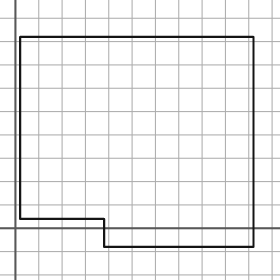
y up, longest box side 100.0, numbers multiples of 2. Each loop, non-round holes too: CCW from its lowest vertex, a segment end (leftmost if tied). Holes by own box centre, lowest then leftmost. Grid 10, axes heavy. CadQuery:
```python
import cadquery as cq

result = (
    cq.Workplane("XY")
    .moveTo(38.0, -8.0)
    .lineTo(102.0, -8.0)
    .lineTo(102.0, 82.0)
    .lineTo(2.0, 82.0)
    .lineTo(2.0, 4.0)
    .lineTo(38.0, 4.0)
    .close()
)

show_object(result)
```